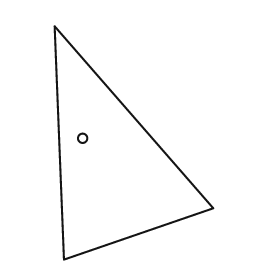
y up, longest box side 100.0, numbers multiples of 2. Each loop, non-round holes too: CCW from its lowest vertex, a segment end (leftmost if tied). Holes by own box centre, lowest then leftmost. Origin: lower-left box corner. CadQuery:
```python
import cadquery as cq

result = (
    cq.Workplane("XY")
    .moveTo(4.0, 0.0)
    .lineTo(68.0, 22.0)
    .lineTo(0.0, 100.0)
    .close()
    .moveTo(12.0, 52.0)
    .circle(2.0)
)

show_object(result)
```